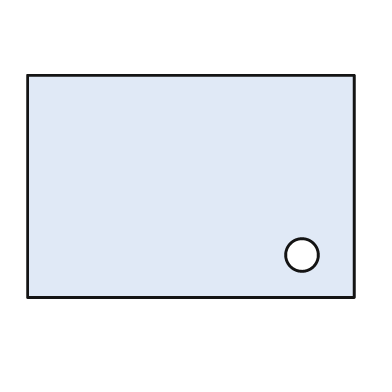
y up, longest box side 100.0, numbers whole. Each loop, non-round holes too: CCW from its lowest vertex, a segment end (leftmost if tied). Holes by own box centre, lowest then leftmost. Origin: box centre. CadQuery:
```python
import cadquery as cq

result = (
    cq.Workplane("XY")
    .moveTo(-50.0, -34.0)
    .lineTo(50.0, -34.0)
    .lineTo(50.0, 34.0)
    .lineTo(-50.0, 34.0)
    .close()
    .moveTo(34.0, -21.0)
    .circle(5.0)
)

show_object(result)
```